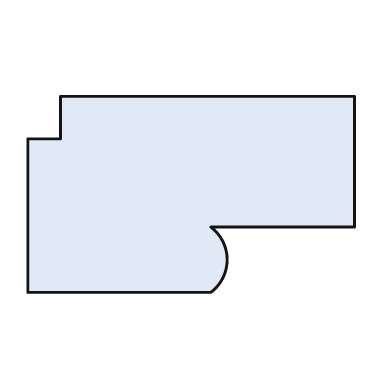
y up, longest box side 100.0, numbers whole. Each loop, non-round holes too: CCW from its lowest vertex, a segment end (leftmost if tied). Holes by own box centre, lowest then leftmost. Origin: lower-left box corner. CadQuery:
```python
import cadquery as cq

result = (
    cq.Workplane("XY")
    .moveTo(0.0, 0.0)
    .lineTo(56.0, 0.0)
    .threePointArc((61.0, 10.0), (56.0, 20.0))
    .lineTo(100.0, 20.0)
    .lineTo(100.0, 60.0)
    .lineTo(10.0, 60.0)
    .lineTo(10.0, 47.0)
    .lineTo(0.0, 47.0)
    .close()
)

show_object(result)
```